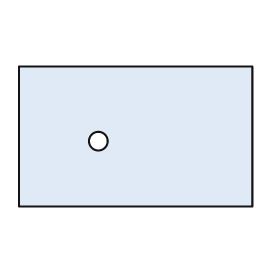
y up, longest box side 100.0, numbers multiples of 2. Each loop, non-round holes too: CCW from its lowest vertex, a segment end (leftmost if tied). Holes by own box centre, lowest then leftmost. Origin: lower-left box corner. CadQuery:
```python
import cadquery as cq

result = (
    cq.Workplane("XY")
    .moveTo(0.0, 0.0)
    .lineTo(100.0, 0.0)
    .lineTo(100.0, 60.0)
    .lineTo(0.0, 60.0)
    .close()
    .moveTo(34.0, 28.0)
    .circle(4.0)
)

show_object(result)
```